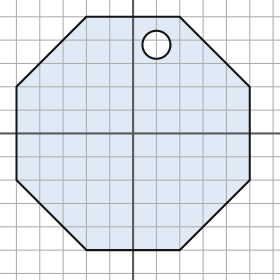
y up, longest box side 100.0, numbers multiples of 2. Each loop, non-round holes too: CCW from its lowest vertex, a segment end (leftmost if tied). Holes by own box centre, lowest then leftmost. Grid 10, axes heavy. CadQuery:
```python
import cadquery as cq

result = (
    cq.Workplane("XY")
    .moveTo(-20.0, -50.0)
    .lineTo(20.0, -50.0)
    .lineTo(50.0, -20.0)
    .lineTo(50.0, 20.0)
    .lineTo(20.0, 50.0)
    .lineTo(-20.0, 50.0)
    .lineTo(-50.0, 20.0)
    .lineTo(-50.0, -20.0)
    .close()
    .moveTo(10.0, 38.0)
    .circle(6.0)
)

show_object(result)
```